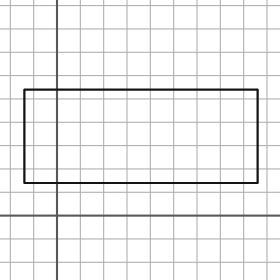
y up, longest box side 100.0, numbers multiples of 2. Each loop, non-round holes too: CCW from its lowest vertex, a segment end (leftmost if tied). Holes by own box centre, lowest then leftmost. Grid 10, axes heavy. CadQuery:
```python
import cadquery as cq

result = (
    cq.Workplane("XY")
    .moveTo(-14.0, 14.0)
    .lineTo(86.0, 14.0)
    .lineTo(86.0, 54.0)
    .lineTo(-14.0, 54.0)
    .close()
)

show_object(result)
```